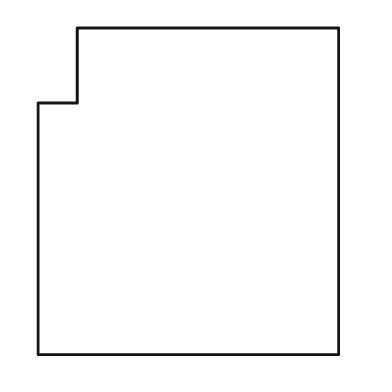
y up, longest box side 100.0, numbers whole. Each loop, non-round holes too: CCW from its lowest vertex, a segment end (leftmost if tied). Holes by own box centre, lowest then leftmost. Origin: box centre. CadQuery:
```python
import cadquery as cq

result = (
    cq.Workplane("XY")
    .moveTo(-46.0, -50.0)
    .lineTo(46.0, -50.0)
    .lineTo(46.0, 50.0)
    .lineTo(-34.0, 50.0)
    .lineTo(-34.0, 27.0)
    .lineTo(-46.0, 27.0)
    .close()
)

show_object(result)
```